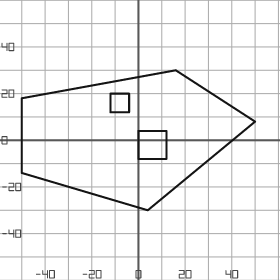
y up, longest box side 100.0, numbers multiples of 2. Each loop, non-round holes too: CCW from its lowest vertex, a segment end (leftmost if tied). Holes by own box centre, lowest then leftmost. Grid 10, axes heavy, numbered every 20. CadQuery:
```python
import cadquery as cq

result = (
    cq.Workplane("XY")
    .moveTo(4.0, -30.0)
    .lineTo(50.0, 8.0)
    .lineTo(16.0, 30.0)
    .lineTo(-50.0, 18.0)
    .lineTo(-50.0, -14.0)
    .close()
    .moveTo(0.0, -8.0)
    .lineTo(12.0, -8.0)
    .lineTo(12.0, 4.0)
    .lineTo(0.0, 4.0)
    .close()
    .moveTo(-12.0, 12.0)
    .lineTo(-4.0, 12.0)
    .lineTo(-4.0, 20.0)
    .lineTo(-12.0, 20.0)
    .close()
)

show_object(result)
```